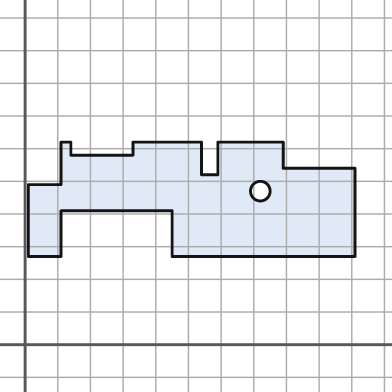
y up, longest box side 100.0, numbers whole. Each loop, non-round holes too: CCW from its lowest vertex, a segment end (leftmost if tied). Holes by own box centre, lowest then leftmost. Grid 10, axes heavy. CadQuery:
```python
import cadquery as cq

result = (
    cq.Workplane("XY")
    .moveTo(1.0, 27.0)
    .lineTo(11.0, 27.0)
    .lineTo(11.0, 41.0)
    .lineTo(45.0, 41.0)
    .lineTo(45.0, 27.0)
    .lineTo(101.0, 27.0)
    .lineTo(101.0, 54.0)
    .lineTo(79.0, 54.0)
    .lineTo(79.0, 62.0)
    .lineTo(59.0, 62.0)
    .lineTo(59.0, 52.0)
    .lineTo(54.0, 52.0)
    .lineTo(54.0, 62.0)
    .lineTo(33.0, 62.0)
    .lineTo(33.0, 58.0)
    .lineTo(14.0, 58.0)
    .lineTo(14.0, 62.0)
    .lineTo(11.0, 62.0)
    .lineTo(11.0, 49.0)
    .lineTo(1.0, 49.0)
    .close()
    .moveTo(72.0, 47.0)
    .circle(3.0)
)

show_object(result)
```